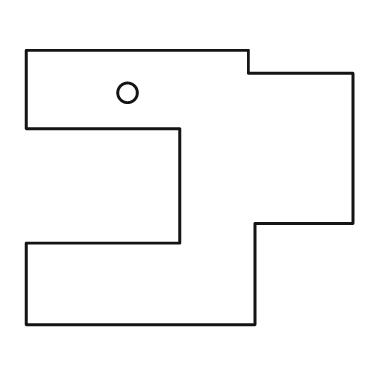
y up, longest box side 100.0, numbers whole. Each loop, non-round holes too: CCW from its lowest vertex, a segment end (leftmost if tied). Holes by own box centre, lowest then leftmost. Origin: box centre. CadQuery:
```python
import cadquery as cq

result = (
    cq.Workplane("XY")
    .moveTo(-50.0, -42.0)
    .lineTo(20.0, -42.0)
    .lineTo(20.0, -11.0)
    .lineTo(50.0, -11.0)
    .lineTo(50.0, 35.0)
    .lineTo(18.0, 35.0)
    .lineTo(18.0, 42.0)
    .lineTo(-50.0, 42.0)
    .lineTo(-50.0, 18.0)
    .lineTo(-3.0, 18.0)
    .lineTo(-3.0, -17.0)
    .lineTo(-50.0, -17.0)
    .close()
    .moveTo(-19.0, 29.0)
    .circle(3.0)
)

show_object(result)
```